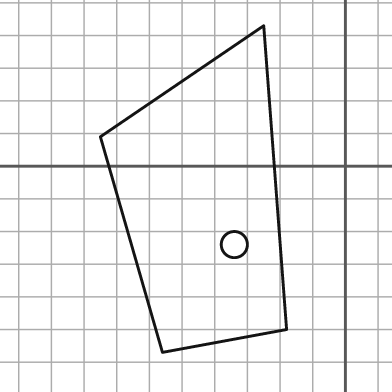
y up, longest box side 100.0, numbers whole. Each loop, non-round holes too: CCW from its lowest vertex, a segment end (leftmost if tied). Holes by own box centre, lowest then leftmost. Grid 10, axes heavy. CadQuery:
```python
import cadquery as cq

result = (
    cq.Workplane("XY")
    .moveTo(-56.0, -57.0)
    .lineTo(-18.0, -50.0)
    .lineTo(-25.0, 43.0)
    .lineTo(-75.0, 9.0)
    .close()
    .moveTo(-34.0, -24.0)
    .circle(4.0)
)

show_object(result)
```